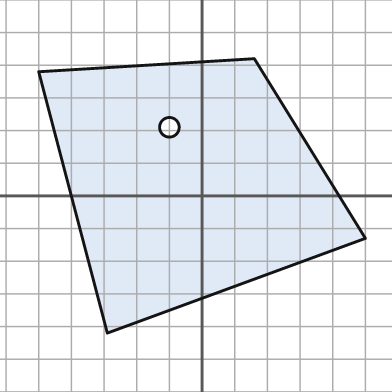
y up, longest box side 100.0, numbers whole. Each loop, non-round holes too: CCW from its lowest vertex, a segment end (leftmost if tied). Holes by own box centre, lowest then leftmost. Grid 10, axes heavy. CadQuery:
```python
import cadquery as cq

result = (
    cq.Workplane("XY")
    .moveTo(-29.0, -42.0)
    .lineTo(50.0, -13.0)
    .lineTo(16.0, 42.0)
    .lineTo(-50.0, 38.0)
    .close()
    .moveTo(-10.0, 21.0)
    .circle(3.0)
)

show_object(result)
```